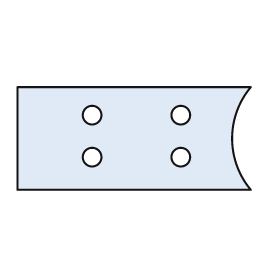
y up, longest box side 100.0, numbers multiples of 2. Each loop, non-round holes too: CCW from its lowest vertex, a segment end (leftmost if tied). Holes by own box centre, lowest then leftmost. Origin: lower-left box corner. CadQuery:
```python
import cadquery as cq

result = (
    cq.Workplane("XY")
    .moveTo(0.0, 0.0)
    .lineTo(100.0, 0.0)
    .threePointArc((92.0, 22.0), (100.0, 44.0))
    .lineTo(0.0, 44.0)
    .close()
    .moveTo(32.0, 14.0)
    .circle(4.0)
    .moveTo(70.0, 14.0)
    .circle(4.0)
    .moveTo(32.0, 32.0)
    .circle(4.0)
    .moveTo(70.0, 32.0)
    .circle(4.0)
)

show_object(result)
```